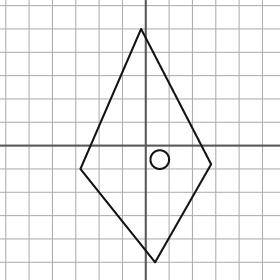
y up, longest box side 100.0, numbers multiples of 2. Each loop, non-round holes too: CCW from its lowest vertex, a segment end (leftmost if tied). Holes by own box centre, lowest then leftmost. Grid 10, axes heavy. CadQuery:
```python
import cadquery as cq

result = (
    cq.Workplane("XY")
    .moveTo(4.0, -50.0)
    .lineTo(28.0, -8.0)
    .lineTo(-2.0, 50.0)
    .lineTo(-28.0, -10.0)
    .close()
    .moveTo(6.0, -6.0)
    .circle(4.0)
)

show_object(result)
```